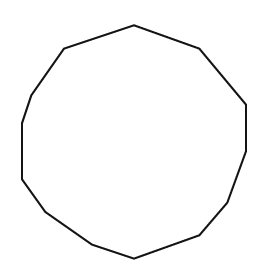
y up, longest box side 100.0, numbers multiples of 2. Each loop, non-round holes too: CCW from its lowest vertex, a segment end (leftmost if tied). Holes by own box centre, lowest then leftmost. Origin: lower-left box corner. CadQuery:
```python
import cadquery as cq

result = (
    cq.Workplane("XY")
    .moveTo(48.0, 0.0)
    .lineTo(76.0, 10.0)
    .lineTo(88.0, 24.0)
    .lineTo(96.0, 46.0)
    .lineTo(96.0, 66.0)
    .lineTo(76.0, 90.0)
    .lineTo(48.0, 100.0)
    .lineTo(18.0, 90.0)
    .lineTo(4.0, 70.0)
    .lineTo(0.0, 58.0)
    .lineTo(0.0, 34.0)
    .lineTo(10.0, 20.0)
    .lineTo(30.0, 6.0)
    .close()
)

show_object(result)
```